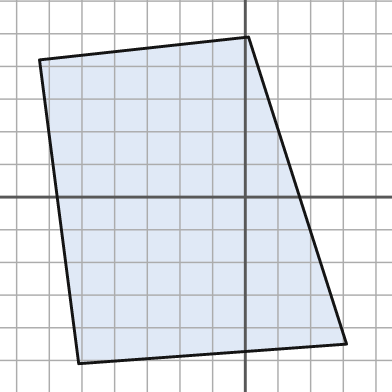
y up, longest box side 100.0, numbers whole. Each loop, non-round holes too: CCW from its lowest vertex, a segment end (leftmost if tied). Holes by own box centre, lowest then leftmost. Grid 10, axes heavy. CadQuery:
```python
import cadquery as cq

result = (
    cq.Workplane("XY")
    .moveTo(-51.0, -51.0)
    .lineTo(31.0, -45.0)
    .lineTo(1.0, 49.0)
    .lineTo(-63.0, 42.0)
    .close()
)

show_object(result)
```